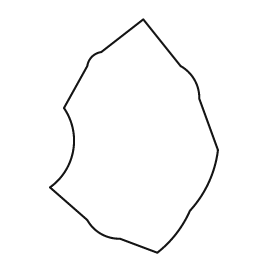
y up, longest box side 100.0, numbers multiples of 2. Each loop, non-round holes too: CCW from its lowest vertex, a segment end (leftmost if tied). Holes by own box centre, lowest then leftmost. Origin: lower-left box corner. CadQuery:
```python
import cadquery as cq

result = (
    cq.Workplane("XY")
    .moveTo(46.0, 0.0)
    .threePointArc((54.0, 8.0), (60.0, 18.0))
    .threePointArc((68.0, 30.0), (72.0, 44.0))
    .lineTo(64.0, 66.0)
    .threePointArc((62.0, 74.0), (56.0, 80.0))
    .lineTo(40.0, 100.0)
    .lineTo(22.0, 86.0)
    .threePointArc((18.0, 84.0), (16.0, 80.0))
    .lineTo(6.0, 62.0)
    .threePointArc((10.0, 44.0), (0.0, 28.0))
    .lineTo(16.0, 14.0)
    .threePointArc((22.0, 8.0), (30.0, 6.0))
    .close()
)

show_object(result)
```